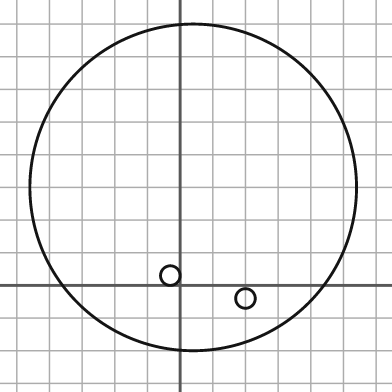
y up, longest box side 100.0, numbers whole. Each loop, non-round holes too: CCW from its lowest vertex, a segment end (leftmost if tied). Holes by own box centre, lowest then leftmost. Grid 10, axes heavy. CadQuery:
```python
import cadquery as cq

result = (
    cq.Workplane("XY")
    .moveTo(4.0, 30.0)
    .circle(50.0)
    .moveTo(20.0, -4.0)
    .circle(3.0)
    .moveTo(-3.0, 3.0)
    .circle(3.0)
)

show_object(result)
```